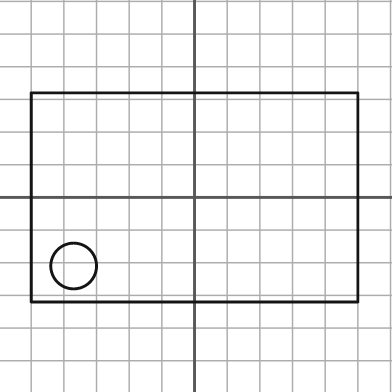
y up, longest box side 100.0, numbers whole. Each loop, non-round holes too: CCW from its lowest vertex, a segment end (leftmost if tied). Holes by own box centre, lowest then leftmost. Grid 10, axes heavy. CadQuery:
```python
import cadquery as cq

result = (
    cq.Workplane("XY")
    .moveTo(-50.0, -32.0)
    .lineTo(50.0, -32.0)
    .lineTo(50.0, 32.0)
    .lineTo(-50.0, 32.0)
    .close()
    .moveTo(-37.0, -21.0)
    .circle(7.0)
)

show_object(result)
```